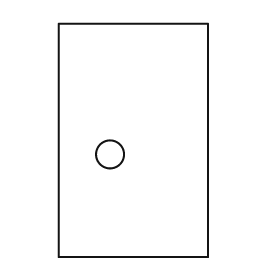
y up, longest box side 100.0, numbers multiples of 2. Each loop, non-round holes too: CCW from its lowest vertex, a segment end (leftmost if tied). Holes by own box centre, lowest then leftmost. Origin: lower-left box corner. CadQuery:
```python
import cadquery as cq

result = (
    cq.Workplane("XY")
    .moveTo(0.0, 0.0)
    .lineTo(64.0, 0.0)
    .lineTo(64.0, 100.0)
    .lineTo(0.0, 100.0)
    .close()
    .moveTo(22.0, 44.0)
    .circle(6.0)
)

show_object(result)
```